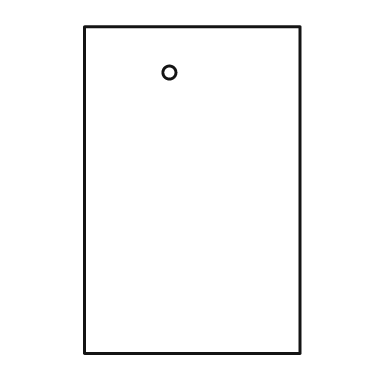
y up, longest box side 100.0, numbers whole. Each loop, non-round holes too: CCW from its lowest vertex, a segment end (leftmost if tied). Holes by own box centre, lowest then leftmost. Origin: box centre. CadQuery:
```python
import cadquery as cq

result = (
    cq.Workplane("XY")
    .moveTo(-33.0, -50.0)
    .lineTo(33.0, -50.0)
    .lineTo(33.0, 50.0)
    .lineTo(-33.0, 50.0)
    .close()
    .moveTo(-7.0, 36.0)
    .circle(2.0)
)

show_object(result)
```